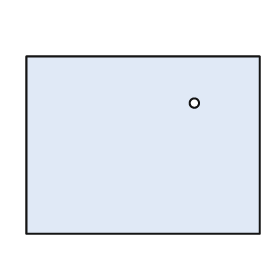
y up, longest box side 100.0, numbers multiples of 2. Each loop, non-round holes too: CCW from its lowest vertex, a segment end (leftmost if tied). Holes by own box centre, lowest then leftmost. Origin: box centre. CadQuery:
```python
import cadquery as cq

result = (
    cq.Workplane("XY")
    .moveTo(-50.0, -38.0)
    .lineTo(50.0, -38.0)
    .lineTo(50.0, 38.0)
    .lineTo(-50.0, 38.0)
    .close()
    .moveTo(22.0, 18.0)
    .circle(2.0)
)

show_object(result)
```